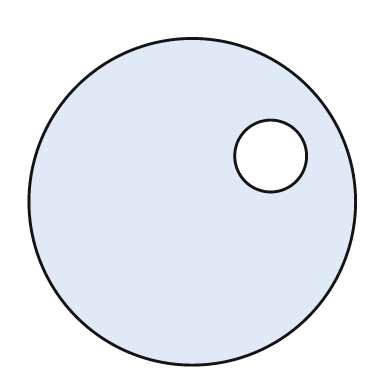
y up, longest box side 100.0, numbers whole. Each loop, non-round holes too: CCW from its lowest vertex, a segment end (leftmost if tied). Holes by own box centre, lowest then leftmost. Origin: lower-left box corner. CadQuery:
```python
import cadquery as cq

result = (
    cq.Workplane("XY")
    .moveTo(50.0, 50.0)
    .circle(50.0)
    .moveTo(74.0, 64.0)
    .circle(11.0)
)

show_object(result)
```